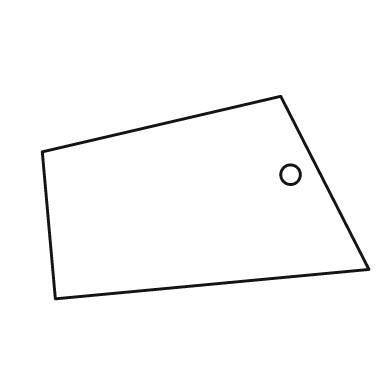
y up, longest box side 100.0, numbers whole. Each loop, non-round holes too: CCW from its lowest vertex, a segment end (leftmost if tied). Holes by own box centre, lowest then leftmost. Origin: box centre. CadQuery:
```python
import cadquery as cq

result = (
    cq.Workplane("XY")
    .moveTo(-46.0, -31.0)
    .lineTo(50.0, -22.0)
    .lineTo(23.0, 31.0)
    .lineTo(-50.0, 14.0)
    .close()
    .moveTo(26.0, 7.0)
    .circle(3.0)
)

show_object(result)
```